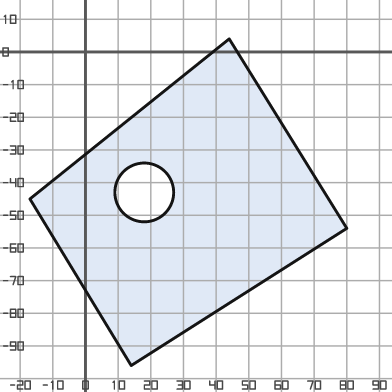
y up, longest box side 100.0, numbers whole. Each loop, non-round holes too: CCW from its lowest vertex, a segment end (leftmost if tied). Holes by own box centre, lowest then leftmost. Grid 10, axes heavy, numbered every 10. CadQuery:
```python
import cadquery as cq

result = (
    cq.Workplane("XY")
    .moveTo(14.0, -96.0)
    .lineTo(80.0, -54.0)
    .lineTo(44.0, 4.0)
    .lineTo(-17.0, -45.0)
    .close()
    .moveTo(18.0, -43.0)
    .circle(9.0)
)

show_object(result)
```